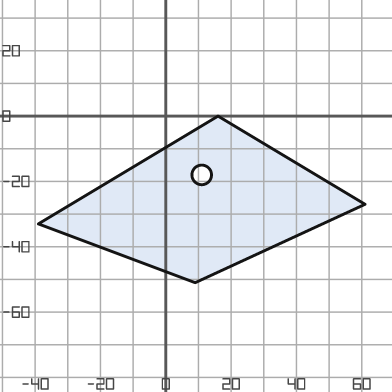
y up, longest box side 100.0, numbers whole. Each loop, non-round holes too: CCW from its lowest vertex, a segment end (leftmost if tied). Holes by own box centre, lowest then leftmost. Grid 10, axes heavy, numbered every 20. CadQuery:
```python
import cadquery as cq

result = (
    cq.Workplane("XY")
    .moveTo(9.0, -51.0)
    .lineTo(61.0, -27.0)
    .lineTo(16.0, 0.0)
    .lineTo(-39.0, -33.0)
    .close()
    .moveTo(11.0, -18.0)
    .circle(3.0)
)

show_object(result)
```